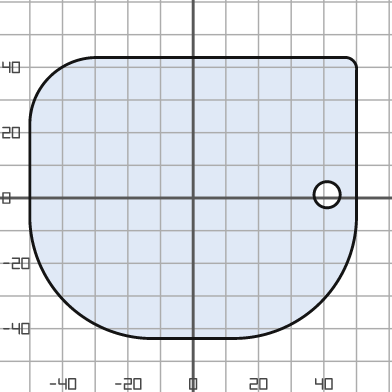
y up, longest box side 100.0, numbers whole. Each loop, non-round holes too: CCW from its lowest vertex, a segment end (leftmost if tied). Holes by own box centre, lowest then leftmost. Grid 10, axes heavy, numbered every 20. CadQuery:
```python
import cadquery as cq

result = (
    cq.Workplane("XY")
    .moveTo(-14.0, -43.0)
    .lineTo(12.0, -43.0)
    .threePointArc((39.0, -32.0), (50.0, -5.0))
    .lineTo(50.0, 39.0)
    .threePointArc((49.0, 42.0), (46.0, 43.0))
    .lineTo(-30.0, 43.0)
    .threePointArc((-44.0, 37.0), (-50.0, 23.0))
    .lineTo(-50.0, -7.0)
    .threePointArc((-39.0, -32.0), (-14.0, -43.0))
    .close()
    .moveTo(41.0, 1.0)
    .circle(4.0)
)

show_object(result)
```